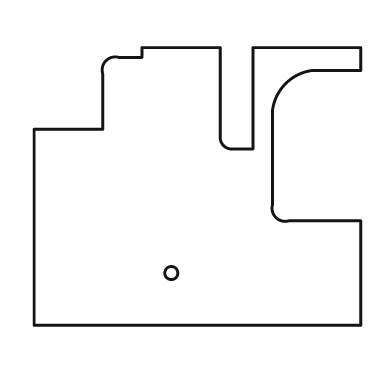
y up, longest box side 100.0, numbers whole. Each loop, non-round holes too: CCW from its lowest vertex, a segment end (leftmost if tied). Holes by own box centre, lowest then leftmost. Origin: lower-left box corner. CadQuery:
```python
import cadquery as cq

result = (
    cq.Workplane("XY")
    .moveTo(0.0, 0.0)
    .lineTo(100.0, 0.0)
    .lineTo(100.0, 32.0)
    .lineTo(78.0, 32.0)
    .threePointArc((74.0, 33.0), (73.0, 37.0))
    .lineTo(73.0, 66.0)
    .threePointArc((77.0, 74.0), (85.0, 78.0))
    .lineTo(100.0, 78.0)
    .lineTo(100.0, 85.0)
    .lineTo(67.0, 85.0)
    .lineTo(67.0, 54.0)
    .lineTo(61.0, 54.0)
    .threePointArc((58.0, 55.0), (57.0, 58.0))
    .lineTo(57.0, 85.0)
    .lineTo(33.0, 85.0)
    .lineTo(33.0, 82.0)
    .lineTo(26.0, 82.0)
    .threePointArc((22.0, 81.0), (21.0, 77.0))
    .lineTo(21.0, 60.0)
    .lineTo(0.0, 60.0)
    .close()
    .moveTo(42.0, 16.0)
    .circle(2.0)
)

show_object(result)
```